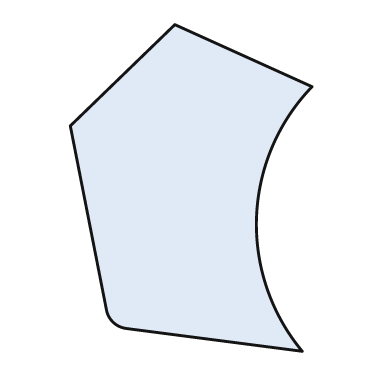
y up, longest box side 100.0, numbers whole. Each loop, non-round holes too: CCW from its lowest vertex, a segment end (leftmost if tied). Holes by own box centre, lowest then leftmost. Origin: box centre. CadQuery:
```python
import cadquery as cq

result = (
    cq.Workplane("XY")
    .moveTo(34.0, -50.0)
    .threePointArc((20.0, -9.0), (37.0, 31.0))
    .lineTo(-5.0, 50.0)
    .lineTo(-37.0, 19.0)
    .lineTo(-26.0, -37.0)
    .threePointArc((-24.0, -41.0), (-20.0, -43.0))
    .close()
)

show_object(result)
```